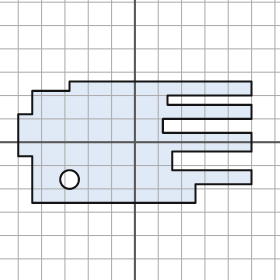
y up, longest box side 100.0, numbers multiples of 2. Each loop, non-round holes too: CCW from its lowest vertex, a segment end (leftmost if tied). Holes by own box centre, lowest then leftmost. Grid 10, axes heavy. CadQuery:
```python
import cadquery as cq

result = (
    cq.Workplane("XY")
    .moveTo(-44.0, -26.0)
    .lineTo(26.0, -26.0)
    .lineTo(26.0, -18.0)
    .lineTo(50.0, -18.0)
    .lineTo(50.0, -12.0)
    .lineTo(16.0, -12.0)
    .lineTo(16.0, -4.0)
    .lineTo(50.0, -4.0)
    .lineTo(50.0, 4.0)
    .lineTo(12.0, 4.0)
    .lineTo(12.0, 10.0)
    .lineTo(50.0, 10.0)
    .lineTo(50.0, 16.0)
    .lineTo(14.0, 16.0)
    .lineTo(14.0, 20.0)
    .lineTo(50.0, 20.0)
    .lineTo(50.0, 26.0)
    .lineTo(-28.0, 26.0)
    .lineTo(-28.0, 22.0)
    .lineTo(-44.0, 22.0)
    .lineTo(-44.0, 12.0)
    .lineTo(-50.0, 12.0)
    .lineTo(-50.0, -6.0)
    .lineTo(-44.0, -6.0)
    .close()
    .moveTo(-28.0, -16.0)
    .circle(4.0)
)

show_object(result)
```